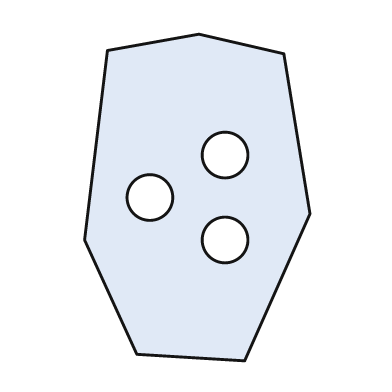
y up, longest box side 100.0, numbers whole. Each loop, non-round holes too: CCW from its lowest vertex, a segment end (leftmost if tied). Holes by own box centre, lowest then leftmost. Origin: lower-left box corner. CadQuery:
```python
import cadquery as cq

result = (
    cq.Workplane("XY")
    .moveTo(49.0, 0.0)
    .lineTo(69.0, 45.0)
    .lineTo(61.0, 94.0)
    .lineTo(35.0, 100.0)
    .lineTo(7.0, 95.0)
    .lineTo(0.0, 37.0)
    .lineTo(16.0, 2.0)
    .close()
    .moveTo(43.0, 37.0)
    .circle(7.0)
    .moveTo(20.0, 50.0)
    .circle(7.0)
    .moveTo(43.0, 63.0)
    .circle(7.0)
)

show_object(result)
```